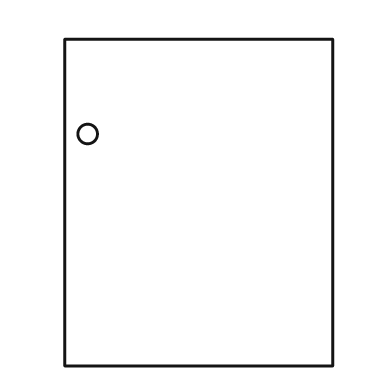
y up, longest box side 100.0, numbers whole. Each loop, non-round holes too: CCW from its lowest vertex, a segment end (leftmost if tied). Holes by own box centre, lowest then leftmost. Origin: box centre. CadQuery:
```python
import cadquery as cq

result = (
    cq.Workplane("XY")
    .moveTo(-41.0, -50.0)
    .lineTo(41.0, -50.0)
    .lineTo(41.0, 50.0)
    .lineTo(-41.0, 50.0)
    .close()
    .moveTo(-34.0, 21.0)
    .circle(3.0)
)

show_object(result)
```